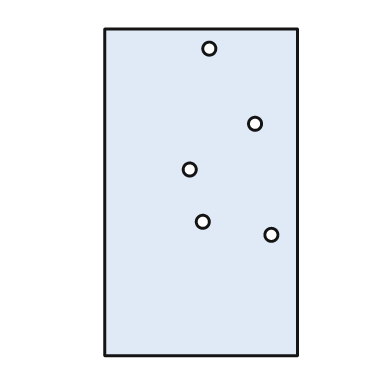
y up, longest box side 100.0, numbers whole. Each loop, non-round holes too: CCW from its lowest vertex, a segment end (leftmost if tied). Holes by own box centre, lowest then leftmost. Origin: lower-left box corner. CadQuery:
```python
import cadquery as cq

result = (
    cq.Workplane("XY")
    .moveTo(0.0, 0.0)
    .lineTo(59.0, 0.0)
    .lineTo(59.0, 100.0)
    .lineTo(0.0, 100.0)
    .close()
    .moveTo(51.0, 37.0)
    .circle(2.0)
    .moveTo(30.0, 41.0)
    .circle(2.0)
    .moveTo(26.0, 57.0)
    .circle(2.0)
    .moveTo(46.0, 71.0)
    .circle(2.0)
    .moveTo(32.0, 94.0)
    .circle(2.0)
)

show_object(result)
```